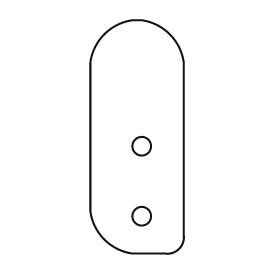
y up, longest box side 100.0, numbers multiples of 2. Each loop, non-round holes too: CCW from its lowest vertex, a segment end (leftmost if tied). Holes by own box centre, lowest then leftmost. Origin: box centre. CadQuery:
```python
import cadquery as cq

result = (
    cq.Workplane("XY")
    .moveTo(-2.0, -50.0)
    .lineTo(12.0, -50.0)
    .threePointArc((18.0, -48.0), (20.0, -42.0))
    .lineTo(20.0, 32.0)
    .threePointArc((14.0, 44.0), (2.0, 50.0))
    .lineTo(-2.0, 50.0)
    .threePointArc((-14.0, 44.0), (-20.0, 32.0))
    .lineTo(-20.0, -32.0)
    .threePointArc((-14.0, -44.0), (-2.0, -50.0))
    .close()
    .moveTo(2.0, -34.0)
    .circle(4.0)
    .moveTo(2.0, -4.0)
    .circle(4.0)
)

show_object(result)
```